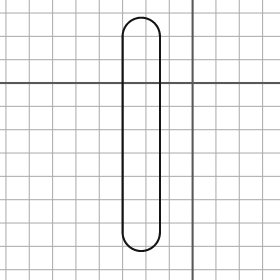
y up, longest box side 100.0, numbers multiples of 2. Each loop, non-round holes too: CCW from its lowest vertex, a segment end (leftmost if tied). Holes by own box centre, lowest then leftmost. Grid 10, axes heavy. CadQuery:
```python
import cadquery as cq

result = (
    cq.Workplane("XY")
    .moveTo(-30.0, -64.0)
    .threePointArc((-22.0, -72.0), (-14.0, -64.0))
    .lineTo(-14.0, 20.0)
    .threePointArc((-22.0, 28.0), (-30.0, 20.0))
    .close()
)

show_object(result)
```